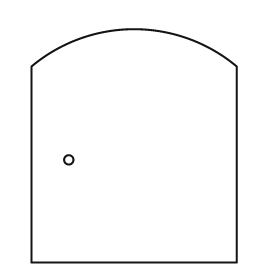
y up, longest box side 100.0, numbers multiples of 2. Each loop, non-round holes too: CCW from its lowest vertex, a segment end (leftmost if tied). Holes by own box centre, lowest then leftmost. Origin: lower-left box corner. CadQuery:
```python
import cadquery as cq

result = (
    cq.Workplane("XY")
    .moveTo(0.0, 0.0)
    .lineTo(88.0, 0.0)
    .lineTo(88.0, 84.0)
    .threePointArc((44.0, 100.0), (0.0, 84.0))
    .close()
    .moveTo(16.0, 44.0)
    .circle(2.0)
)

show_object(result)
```